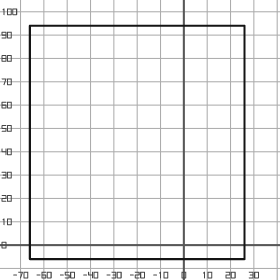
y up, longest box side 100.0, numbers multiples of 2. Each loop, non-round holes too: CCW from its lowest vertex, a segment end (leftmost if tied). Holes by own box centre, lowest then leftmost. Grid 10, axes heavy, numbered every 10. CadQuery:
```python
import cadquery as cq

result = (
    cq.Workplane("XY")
    .moveTo(-66.0, -6.0)
    .lineTo(26.0, -6.0)
    .lineTo(26.0, 94.0)
    .lineTo(-66.0, 94.0)
    .close()
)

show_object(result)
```